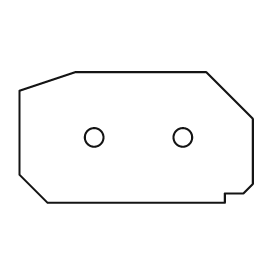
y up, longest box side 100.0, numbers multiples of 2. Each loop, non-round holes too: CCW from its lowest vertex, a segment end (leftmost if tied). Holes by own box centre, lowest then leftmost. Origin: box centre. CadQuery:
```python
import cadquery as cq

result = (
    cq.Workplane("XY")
    .moveTo(-38.0, -28.0)
    .lineTo(38.0, -28.0)
    .lineTo(38.0, -24.0)
    .lineTo(46.0, -24.0)
    .lineTo(50.0, -20.0)
    .lineTo(50.0, 8.0)
    .lineTo(30.0, 28.0)
    .lineTo(-26.0, 28.0)
    .lineTo(-50.0, 20.0)
    .lineTo(-50.0, -16.0)
    .close()
    .moveTo(-18.0, 0.0)
    .circle(4.0)
    .moveTo(20.0, 0.0)
    .circle(4.0)
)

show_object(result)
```